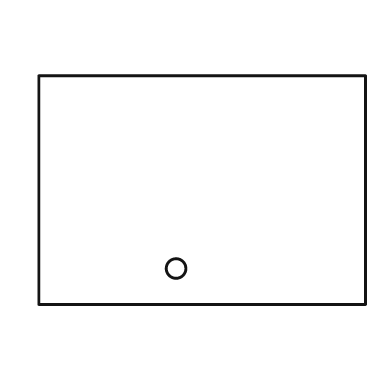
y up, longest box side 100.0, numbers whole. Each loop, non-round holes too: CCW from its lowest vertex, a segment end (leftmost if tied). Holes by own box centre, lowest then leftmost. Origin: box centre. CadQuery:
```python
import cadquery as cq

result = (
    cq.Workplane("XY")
    .moveTo(-50.0, -35.0)
    .lineTo(50.0, -35.0)
    .lineTo(50.0, 35.0)
    .lineTo(-50.0, 35.0)
    .close()
    .moveTo(-8.0, -24.0)
    .circle(3.0)
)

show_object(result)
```